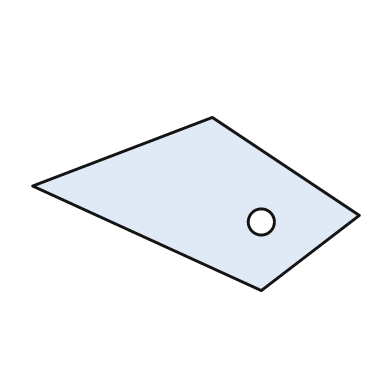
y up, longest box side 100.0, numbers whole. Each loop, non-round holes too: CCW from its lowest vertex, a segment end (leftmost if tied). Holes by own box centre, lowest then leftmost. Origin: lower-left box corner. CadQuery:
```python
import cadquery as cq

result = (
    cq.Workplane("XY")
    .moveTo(70.0, 0.0)
    .lineTo(100.0, 23.0)
    .lineTo(55.0, 53.0)
    .lineTo(0.0, 32.0)
    .close()
    .moveTo(70.0, 21.0)
    .circle(4.0)
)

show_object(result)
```